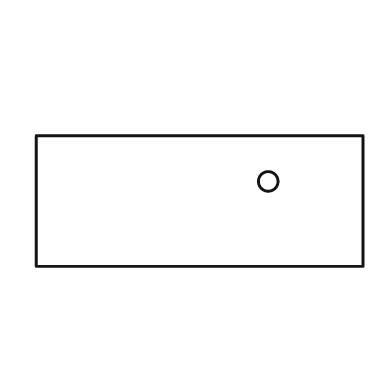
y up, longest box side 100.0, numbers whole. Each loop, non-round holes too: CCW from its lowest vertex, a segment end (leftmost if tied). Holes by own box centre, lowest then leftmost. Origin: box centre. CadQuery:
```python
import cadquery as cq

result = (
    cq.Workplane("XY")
    .moveTo(-50.0, -20.0)
    .lineTo(50.0, -20.0)
    .lineTo(50.0, 20.0)
    .lineTo(-50.0, 20.0)
    .close()
    .moveTo(21.0, 6.0)
    .circle(3.0)
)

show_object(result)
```